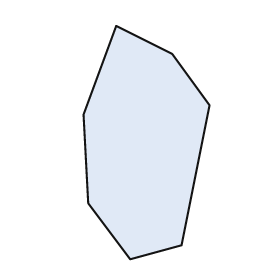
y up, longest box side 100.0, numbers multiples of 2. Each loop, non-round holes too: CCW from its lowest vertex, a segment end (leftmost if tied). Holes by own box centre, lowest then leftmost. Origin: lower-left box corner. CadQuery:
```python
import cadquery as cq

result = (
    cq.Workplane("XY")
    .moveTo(20.0, 0.0)
    .lineTo(42.0, 6.0)
    .lineTo(54.0, 66.0)
    .lineTo(38.0, 88.0)
    .lineTo(14.0, 100.0)
    .lineTo(0.0, 62.0)
    .lineTo(2.0, 24.0)
    .close()
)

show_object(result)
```